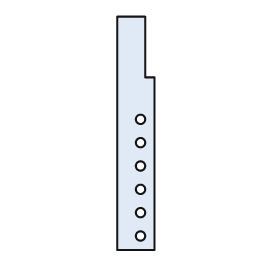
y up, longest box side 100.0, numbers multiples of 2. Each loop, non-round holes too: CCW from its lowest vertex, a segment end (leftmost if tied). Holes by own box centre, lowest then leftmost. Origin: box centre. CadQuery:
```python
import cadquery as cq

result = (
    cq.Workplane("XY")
    .moveTo(-8.0, -50.0)
    .lineTo(8.0, -50.0)
    .lineTo(8.0, 24.0)
    .lineTo(4.0, 24.0)
    .lineTo(4.0, 50.0)
    .lineTo(-8.0, 50.0)
    .close()
    .moveTo(2.0, -44.0)
    .circle(2.0)
    .moveTo(2.0, -34.0)
    .circle(2.0)
    .moveTo(2.0, -24.0)
    .circle(2.0)
    .moveTo(2.0, -14.0)
    .circle(2.0)
    .moveTo(2.0, -4.0)
    .circle(2.0)
    .moveTo(2.0, 6.0)
    .circle(2.0)
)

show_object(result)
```